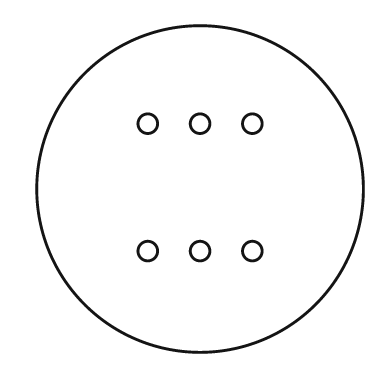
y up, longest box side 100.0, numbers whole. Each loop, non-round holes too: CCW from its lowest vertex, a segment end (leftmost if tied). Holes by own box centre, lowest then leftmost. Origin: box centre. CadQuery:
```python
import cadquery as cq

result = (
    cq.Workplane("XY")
    .moveTo(0.0, 0.0)
    .circle(50.0)
    .moveTo(-16.0, -19.0)
    .circle(3.0)
    .moveTo(0.0, -19.0)
    .circle(3.0)
    .moveTo(16.0, -19.0)
    .circle(3.0)
    .moveTo(-16.0, 20.0)
    .circle(3.0)
    .moveTo(0.0, 20.0)
    .circle(3.0)
    .moveTo(16.0, 20.0)
    .circle(3.0)
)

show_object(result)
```